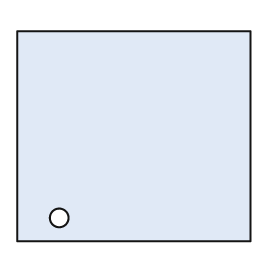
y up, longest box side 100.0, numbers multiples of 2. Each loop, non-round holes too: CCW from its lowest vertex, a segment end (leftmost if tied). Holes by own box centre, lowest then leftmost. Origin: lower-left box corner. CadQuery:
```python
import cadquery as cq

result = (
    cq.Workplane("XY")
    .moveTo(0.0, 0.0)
    .lineTo(100.0, 0.0)
    .lineTo(100.0, 90.0)
    .lineTo(0.0, 90.0)
    .close()
    .moveTo(18.0, 10.0)
    .circle(4.0)
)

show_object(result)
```